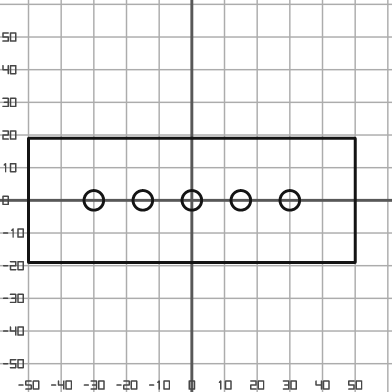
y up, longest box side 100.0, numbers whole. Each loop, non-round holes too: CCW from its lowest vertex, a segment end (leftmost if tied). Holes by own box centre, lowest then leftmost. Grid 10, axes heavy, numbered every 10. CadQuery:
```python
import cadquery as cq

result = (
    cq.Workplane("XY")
    .moveTo(-50.0, -19.0)
    .lineTo(50.0, -19.0)
    .lineTo(50.0, 19.0)
    .lineTo(-50.0, 19.0)
    .close()
    .moveTo(-30.0, 0.0)
    .circle(3.0)
    .moveTo(-15.0, 0.0)
    .circle(3.0)
    .moveTo(0.0, 0.0)
    .circle(3.0)
    .moveTo(15.0, 0.0)
    .circle(3.0)
    .moveTo(30.0, 0.0)
    .circle(3.0)
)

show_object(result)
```